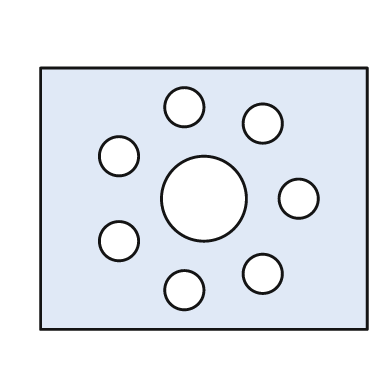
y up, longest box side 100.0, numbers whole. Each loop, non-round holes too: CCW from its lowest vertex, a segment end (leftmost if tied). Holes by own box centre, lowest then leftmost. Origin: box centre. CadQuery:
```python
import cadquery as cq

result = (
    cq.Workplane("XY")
    .moveTo(-50.0, -40.0)
    .lineTo(50.0, -40.0)
    .lineTo(50.0, 40.0)
    .lineTo(-50.0, 40.0)
    .close()
    .moveTo(-6.0, -28.0)
    .circle(6.0)
    .moveTo(18.0, -23.0)
    .circle(6.0)
    .moveTo(-26.0, -13.0)
    .circle(6.0)
    .moveTo(0.0, 0.0)
    .circle(13.0)
    .moveTo(29.0, 0.0)
    .circle(6.0)
    .moveTo(-26.0, 13.0)
    .circle(6.0)
    .moveTo(18.0, 23.0)
    .circle(6.0)
    .moveTo(-6.0, 28.0)
    .circle(6.0)
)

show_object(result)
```